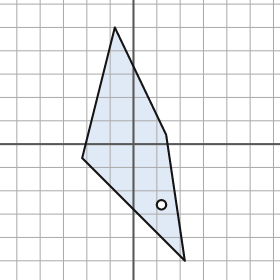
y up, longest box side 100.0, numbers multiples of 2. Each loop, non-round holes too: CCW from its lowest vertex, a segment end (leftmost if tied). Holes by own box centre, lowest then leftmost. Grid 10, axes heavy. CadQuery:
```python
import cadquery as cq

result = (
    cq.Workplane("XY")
    .moveTo(22.0, -50.0)
    .lineTo(14.0, 4.0)
    .lineTo(-8.0, 50.0)
    .lineTo(-22.0, -6.0)
    .close()
    .moveTo(12.0, -26.0)
    .circle(2.0)
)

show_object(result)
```